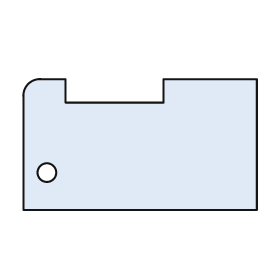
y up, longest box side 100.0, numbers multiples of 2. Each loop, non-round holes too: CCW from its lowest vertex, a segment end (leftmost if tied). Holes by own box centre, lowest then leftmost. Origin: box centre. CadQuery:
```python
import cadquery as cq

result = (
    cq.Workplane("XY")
    .moveTo(-50.0, -28.0)
    .lineTo(50.0, -28.0)
    .lineTo(50.0, 28.0)
    .lineTo(10.0, 28.0)
    .lineTo(10.0, 18.0)
    .lineTo(-32.0, 18.0)
    .lineTo(-32.0, 28.0)
    .lineTo(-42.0, 28.0)
    .threePointArc((-48.0, 26.0), (-50.0, 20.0))
    .close()
    .moveTo(-40.0, -12.0)
    .circle(4.0)
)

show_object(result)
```